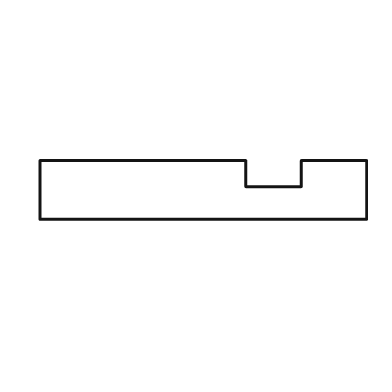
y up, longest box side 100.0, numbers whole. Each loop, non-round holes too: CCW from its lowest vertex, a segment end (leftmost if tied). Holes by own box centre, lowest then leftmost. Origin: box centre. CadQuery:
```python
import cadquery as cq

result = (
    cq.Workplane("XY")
    .moveTo(-50.0, -9.0)
    .lineTo(50.0, -9.0)
    .lineTo(50.0, 9.0)
    .lineTo(30.0, 9.0)
    .lineTo(30.0, 1.0)
    .lineTo(13.0, 1.0)
    .lineTo(13.0, 9.0)
    .lineTo(-50.0, 9.0)
    .close()
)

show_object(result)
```